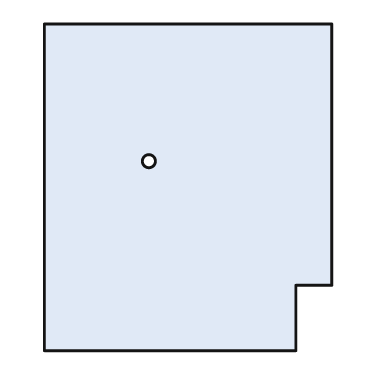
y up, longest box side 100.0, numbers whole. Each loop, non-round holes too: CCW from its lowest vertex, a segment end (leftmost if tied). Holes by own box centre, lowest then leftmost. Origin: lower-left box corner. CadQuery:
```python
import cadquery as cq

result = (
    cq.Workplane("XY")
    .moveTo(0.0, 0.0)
    .lineTo(77.0, 0.0)
    .lineTo(77.0, 20.0)
    .lineTo(88.0, 20.0)
    .lineTo(88.0, 100.0)
    .lineTo(0.0, 100.0)
    .close()
    .moveTo(32.0, 58.0)
    .circle(2.0)
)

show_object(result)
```